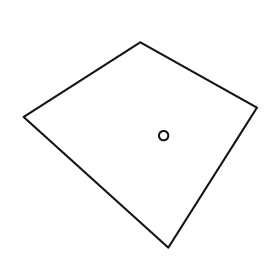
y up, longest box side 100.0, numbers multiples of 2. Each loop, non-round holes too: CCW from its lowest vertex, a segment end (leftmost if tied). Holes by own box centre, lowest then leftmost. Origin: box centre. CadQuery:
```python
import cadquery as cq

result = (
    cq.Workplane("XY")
    .moveTo(12.0, -44.0)
    .lineTo(50.0, 16.0)
    .lineTo(0.0, 44.0)
    .lineTo(-50.0, 12.0)
    .close()
    .moveTo(10.0, 4.0)
    .circle(2.0)
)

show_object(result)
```